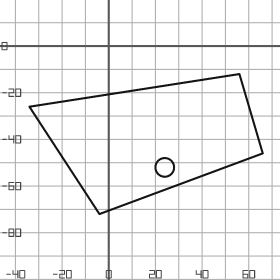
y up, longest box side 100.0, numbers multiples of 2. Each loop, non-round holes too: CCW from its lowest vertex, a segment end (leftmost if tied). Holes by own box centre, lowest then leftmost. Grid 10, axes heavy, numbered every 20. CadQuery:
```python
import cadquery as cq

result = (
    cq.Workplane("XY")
    .moveTo(-4.0, -72.0)
    .lineTo(66.0, -46.0)
    .lineTo(56.0, -12.0)
    .lineTo(-34.0, -26.0)
    .close()
    .moveTo(24.0, -52.0)
    .circle(4.0)
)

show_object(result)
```